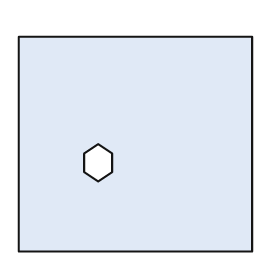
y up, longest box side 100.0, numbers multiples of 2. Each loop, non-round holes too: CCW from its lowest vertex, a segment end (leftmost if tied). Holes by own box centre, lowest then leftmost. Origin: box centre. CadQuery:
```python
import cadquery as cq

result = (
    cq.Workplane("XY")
    .moveTo(-50.0, -46.0)
    .lineTo(50.0, -46.0)
    .lineTo(50.0, 46.0)
    .lineTo(-50.0, 46.0)
    .close()
    .moveTo(-16.0, -16.0)
    .lineTo(-10.0, -12.0)
    .lineTo(-10.0, -4.0)
    .lineTo(-16.0, 0.0)
    .lineTo(-22.0, -4.0)
    .lineTo(-22.0, -12.0)
    .close()
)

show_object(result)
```